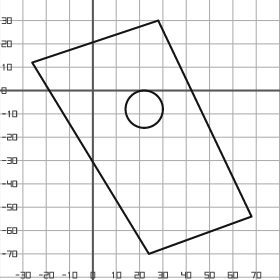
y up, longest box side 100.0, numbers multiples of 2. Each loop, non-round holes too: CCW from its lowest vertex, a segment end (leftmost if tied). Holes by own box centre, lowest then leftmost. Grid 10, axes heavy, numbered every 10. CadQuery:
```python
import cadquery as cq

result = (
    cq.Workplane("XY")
    .moveTo(24.0, -70.0)
    .lineTo(68.0, -54.0)
    .lineTo(28.0, 30.0)
    .lineTo(-26.0, 12.0)
    .close()
    .moveTo(22.0, -8.0)
    .circle(8.0)
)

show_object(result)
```